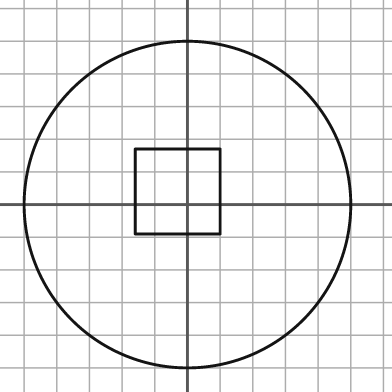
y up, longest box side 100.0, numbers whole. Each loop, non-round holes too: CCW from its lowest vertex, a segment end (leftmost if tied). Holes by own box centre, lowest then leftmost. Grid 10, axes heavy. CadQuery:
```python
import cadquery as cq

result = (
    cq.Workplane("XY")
    .moveTo(0.0, 0.0)
    .circle(50.0)
    .moveTo(-16.0, -9.0)
    .lineTo(10.0, -9.0)
    .lineTo(10.0, 17.0)
    .lineTo(-16.0, 17.0)
    .close()
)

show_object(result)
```